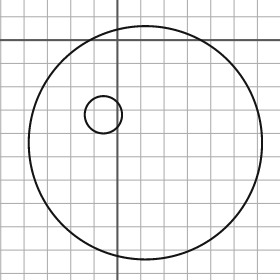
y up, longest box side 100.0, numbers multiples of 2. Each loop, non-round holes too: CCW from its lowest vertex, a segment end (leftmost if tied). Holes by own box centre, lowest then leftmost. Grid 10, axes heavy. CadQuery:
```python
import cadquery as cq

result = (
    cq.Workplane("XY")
    .moveTo(12.0, -44.0)
    .circle(50.0)
    .moveTo(-6.0, -32.0)
    .circle(8.0)
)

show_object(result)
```